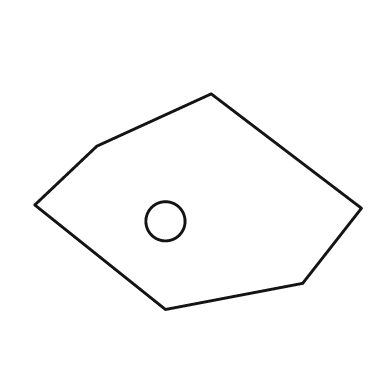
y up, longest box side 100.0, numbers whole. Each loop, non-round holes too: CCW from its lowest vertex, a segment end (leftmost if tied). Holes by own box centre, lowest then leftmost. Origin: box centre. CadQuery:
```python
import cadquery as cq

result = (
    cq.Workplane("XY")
    .moveTo(-10.0, -33.0)
    .lineTo(32.0, -25.0)
    .lineTo(50.0, -2.0)
    .lineTo(4.0, 33.0)
    .lineTo(-31.0, 17.0)
    .lineTo(-50.0, -1.0)
    .close()
    .moveTo(-10.0, -6.0)
    .circle(6.0)
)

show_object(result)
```